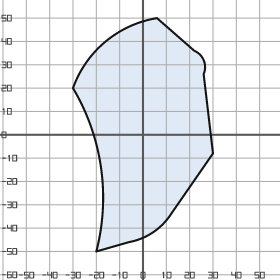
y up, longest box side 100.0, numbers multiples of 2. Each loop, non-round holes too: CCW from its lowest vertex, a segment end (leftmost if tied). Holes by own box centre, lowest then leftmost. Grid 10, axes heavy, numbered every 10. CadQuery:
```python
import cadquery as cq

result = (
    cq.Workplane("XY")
    .moveTo(-20.0, -50.0)
    .lineTo(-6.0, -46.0)
    .threePointArc((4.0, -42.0), (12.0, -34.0))
    .lineTo(30.0, -8.0)
    .lineTo(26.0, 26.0)
    .threePointArc((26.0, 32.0), (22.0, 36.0))
    .lineTo(6.0, 50.0)
    .threePointArc((-16.0, 40.0), (-30.0, 20.0))
    .threePointArc((-18.0, -14.0), (-20.0, -50.0))
    .close()
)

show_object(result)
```